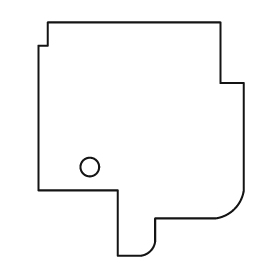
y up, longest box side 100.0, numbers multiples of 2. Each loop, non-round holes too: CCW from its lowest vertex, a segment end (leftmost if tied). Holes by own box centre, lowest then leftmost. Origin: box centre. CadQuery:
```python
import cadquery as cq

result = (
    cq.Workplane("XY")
    .moveTo(-10.0, -50.0)
    .lineTo(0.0, -50.0)
    .threePointArc((4.0, -48.0), (6.0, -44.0))
    .lineTo(6.0, -34.0)
    .lineTo(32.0, -34.0)
    .threePointArc((40.0, -30.0), (44.0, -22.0))
    .lineTo(44.0, 24.0)
    .lineTo(34.0, 24.0)
    .lineTo(34.0, 50.0)
    .lineTo(-40.0, 50.0)
    .lineTo(-40.0, 40.0)
    .lineTo(-44.0, 40.0)
    .lineTo(-44.0, -22.0)
    .lineTo(-10.0, -22.0)
    .close()
    .moveTo(-22.0, -12.0)
    .circle(4.0)
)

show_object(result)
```